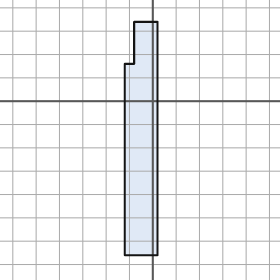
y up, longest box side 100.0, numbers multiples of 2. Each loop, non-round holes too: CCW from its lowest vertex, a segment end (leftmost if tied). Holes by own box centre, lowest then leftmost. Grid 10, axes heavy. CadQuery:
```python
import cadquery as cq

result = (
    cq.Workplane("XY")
    .moveTo(-12.0, -66.0)
    .lineTo(2.0, -66.0)
    .lineTo(2.0, 34.0)
    .lineTo(-8.0, 34.0)
    .lineTo(-8.0, 16.0)
    .lineTo(-12.0, 16.0)
    .close()
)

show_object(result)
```